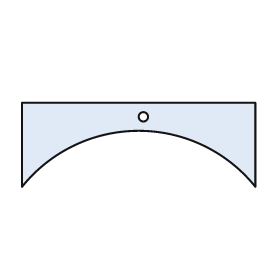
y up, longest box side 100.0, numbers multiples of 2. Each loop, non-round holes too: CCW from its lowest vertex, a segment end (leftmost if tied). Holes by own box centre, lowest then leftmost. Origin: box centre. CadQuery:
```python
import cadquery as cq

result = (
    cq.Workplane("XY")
    .moveTo(-50.0, -18.0)
    .threePointArc((0.0, 6.0), (50.0, -18.0))
    .lineTo(50.0, 18.0)
    .lineTo(-50.0, 18.0)
    .close()
    .moveTo(2.0, 12.0)
    .circle(2.0)
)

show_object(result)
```